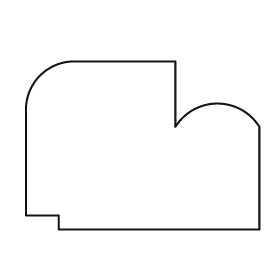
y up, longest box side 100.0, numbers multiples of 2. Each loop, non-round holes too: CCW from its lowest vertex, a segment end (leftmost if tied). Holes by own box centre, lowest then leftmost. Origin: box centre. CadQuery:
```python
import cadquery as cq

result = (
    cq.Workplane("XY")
    .moveTo(-36.0, -36.0)
    .lineTo(50.0, -36.0)
    .lineTo(50.0, 8.0)
    .threePointArc((32.0, 18.0), (14.0, 8.0))
    .lineTo(14.0, 36.0)
    .lineTo(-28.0, 36.0)
    .threePointArc((-44.0, 30.0), (-50.0, 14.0))
    .lineTo(-50.0, -30.0)
    .lineTo(-36.0, -30.0)
    .close()
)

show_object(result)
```